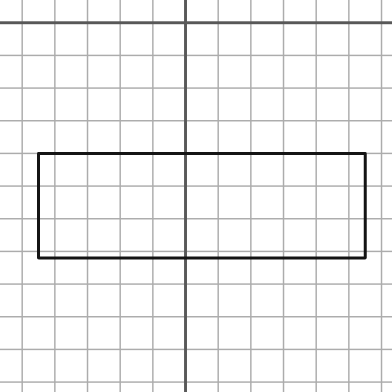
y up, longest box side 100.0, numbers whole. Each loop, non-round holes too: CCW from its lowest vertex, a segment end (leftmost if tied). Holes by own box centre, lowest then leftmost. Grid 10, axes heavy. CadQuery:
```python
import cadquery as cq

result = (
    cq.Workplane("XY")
    .moveTo(-45.0, -72.0)
    .lineTo(55.0, -72.0)
    .lineTo(55.0, -40.0)
    .lineTo(-45.0, -40.0)
    .close()
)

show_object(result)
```